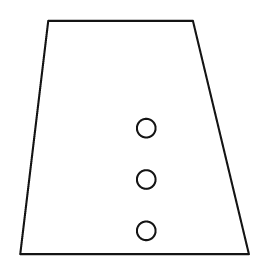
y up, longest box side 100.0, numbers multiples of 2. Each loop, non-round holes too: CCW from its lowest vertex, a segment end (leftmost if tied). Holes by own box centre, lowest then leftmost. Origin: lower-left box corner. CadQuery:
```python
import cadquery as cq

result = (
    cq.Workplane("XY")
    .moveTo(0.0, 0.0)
    .lineTo(98.0, 0.0)
    .lineTo(74.0, 100.0)
    .lineTo(12.0, 100.0)
    .close()
    .moveTo(54.0, 10.0)
    .circle(4.0)
    .moveTo(54.0, 32.0)
    .circle(4.0)
    .moveTo(54.0, 54.0)
    .circle(4.0)
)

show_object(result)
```